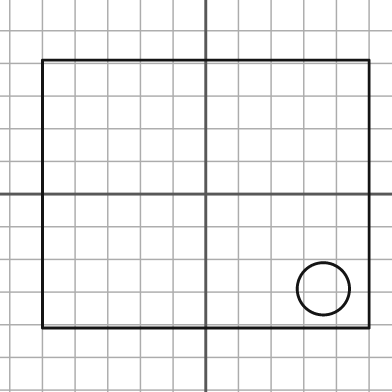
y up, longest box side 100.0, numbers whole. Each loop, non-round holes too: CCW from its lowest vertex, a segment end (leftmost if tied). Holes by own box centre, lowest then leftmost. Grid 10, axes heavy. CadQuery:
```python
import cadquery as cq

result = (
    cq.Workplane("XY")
    .moveTo(-50.0, -41.0)
    .lineTo(50.0, -41.0)
    .lineTo(50.0, 41.0)
    .lineTo(-50.0, 41.0)
    .close()
    .moveTo(36.0, -29.0)
    .circle(8.0)
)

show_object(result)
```